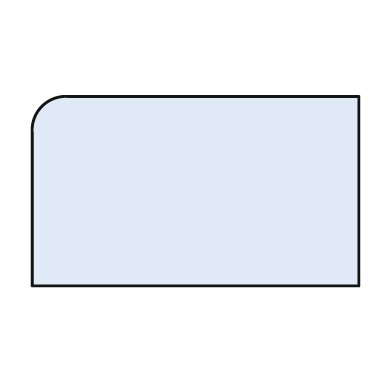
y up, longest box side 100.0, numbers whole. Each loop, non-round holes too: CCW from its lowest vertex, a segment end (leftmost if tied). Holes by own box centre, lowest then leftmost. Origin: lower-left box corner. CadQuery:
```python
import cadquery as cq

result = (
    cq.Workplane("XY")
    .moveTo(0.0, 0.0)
    .lineTo(100.0, 0.0)
    .lineTo(100.0, 58.0)
    .lineTo(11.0, 58.0)
    .threePointArc((3.0, 55.0), (0.0, 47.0))
    .close()
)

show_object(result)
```